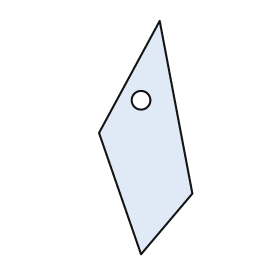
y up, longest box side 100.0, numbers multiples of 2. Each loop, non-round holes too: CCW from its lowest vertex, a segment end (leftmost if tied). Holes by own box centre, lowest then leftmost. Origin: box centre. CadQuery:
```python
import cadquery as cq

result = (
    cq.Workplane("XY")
    .moveTo(-2.0, -50.0)
    .lineTo(20.0, -24.0)
    .lineTo(6.0, 50.0)
    .lineTo(-20.0, 2.0)
    .close()
    .moveTo(-2.0, 16.0)
    .circle(4.0)
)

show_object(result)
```